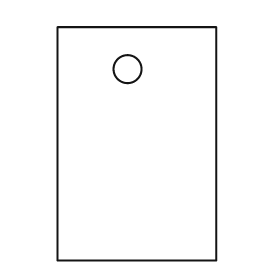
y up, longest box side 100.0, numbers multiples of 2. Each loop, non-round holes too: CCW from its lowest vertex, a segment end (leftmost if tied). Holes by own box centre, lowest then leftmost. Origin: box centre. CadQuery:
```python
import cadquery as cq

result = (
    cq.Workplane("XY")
    .moveTo(-34.0, -50.0)
    .lineTo(34.0, -50.0)
    .lineTo(34.0, 50.0)
    .lineTo(-34.0, 50.0)
    .close()
    .moveTo(-4.0, 32.0)
    .circle(6.0)
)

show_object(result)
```